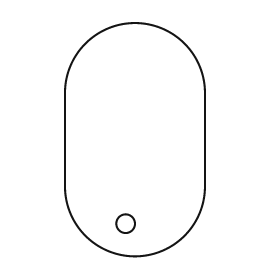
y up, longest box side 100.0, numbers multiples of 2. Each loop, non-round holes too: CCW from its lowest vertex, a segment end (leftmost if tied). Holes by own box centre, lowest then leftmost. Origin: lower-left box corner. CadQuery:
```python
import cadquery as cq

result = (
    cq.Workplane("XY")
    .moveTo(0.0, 30.0)
    .threePointArc((30.0, 0.0), (60.0, 30.0))
    .lineTo(60.0, 70.0)
    .threePointArc((30.0, 100.0), (0.0, 70.0))
    .close()
    .moveTo(26.0, 14.0)
    .circle(4.0)
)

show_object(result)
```